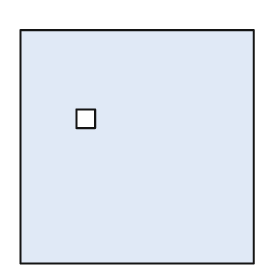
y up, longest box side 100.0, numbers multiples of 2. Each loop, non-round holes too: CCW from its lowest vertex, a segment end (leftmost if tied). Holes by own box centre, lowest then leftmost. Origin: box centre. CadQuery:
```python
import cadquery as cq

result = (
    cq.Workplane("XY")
    .moveTo(-50.0, -50.0)
    .lineTo(50.0, -50.0)
    .lineTo(50.0, 50.0)
    .lineTo(-50.0, 50.0)
    .close()
    .moveTo(-26.0, 8.0)
    .lineTo(-18.0, 8.0)
    .lineTo(-18.0, 16.0)
    .lineTo(-26.0, 16.0)
    .close()
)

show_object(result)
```